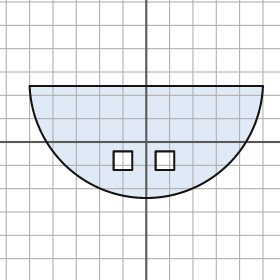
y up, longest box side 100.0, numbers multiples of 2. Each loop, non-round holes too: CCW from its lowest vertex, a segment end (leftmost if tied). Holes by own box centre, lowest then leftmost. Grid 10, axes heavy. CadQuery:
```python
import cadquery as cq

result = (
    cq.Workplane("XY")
    .moveTo(-50.0, 24.0)
    .threePointArc((0.0, -24.0), (50.0, 24.0))
    .close()
    .moveTo(-14.0, -12.0)
    .lineTo(-6.0, -12.0)
    .lineTo(-6.0, -4.0)
    .lineTo(-14.0, -4.0)
    .close()
    .moveTo(4.0, -12.0)
    .lineTo(12.0, -12.0)
    .lineTo(12.0, -4.0)
    .lineTo(4.0, -4.0)
    .close()
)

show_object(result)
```